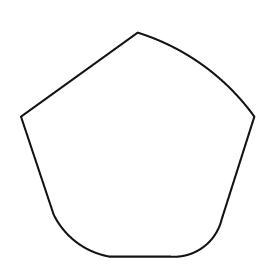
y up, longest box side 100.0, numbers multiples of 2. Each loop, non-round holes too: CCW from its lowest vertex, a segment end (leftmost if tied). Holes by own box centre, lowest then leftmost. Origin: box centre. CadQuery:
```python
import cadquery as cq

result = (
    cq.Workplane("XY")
    .moveTo(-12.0, -48.0)
    .lineTo(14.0, -48.0)
    .threePointArc((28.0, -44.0), (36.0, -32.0))
    .lineTo(50.0, 12.0)
    .threePointArc((28.0, 34.0), (0.0, 48.0))
    .lineTo(-50.0, 12.0)
    .lineTo(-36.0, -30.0)
    .threePointArc((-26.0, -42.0), (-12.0, -48.0))
    .close()
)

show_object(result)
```